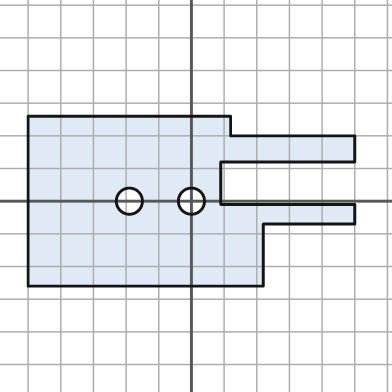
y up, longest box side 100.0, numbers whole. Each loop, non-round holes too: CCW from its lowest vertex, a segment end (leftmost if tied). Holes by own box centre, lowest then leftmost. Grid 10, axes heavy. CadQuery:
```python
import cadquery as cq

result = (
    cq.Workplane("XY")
    .moveTo(-50.0, -26.0)
    .lineTo(22.0, -26.0)
    .lineTo(22.0, -7.0)
    .lineTo(50.0, -7.0)
    .lineTo(50.0, -1.0)
    .lineTo(9.0, -1.0)
    .lineTo(9.0, 12.0)
    .lineTo(50.0, 12.0)
    .lineTo(50.0, 20.0)
    .lineTo(12.0, 20.0)
    .lineTo(12.0, 26.0)
    .lineTo(-50.0, 26.0)
    .close()
    .moveTo(-19.0, 0.0)
    .circle(4.0)
    .moveTo(0.0, 0.0)
    .circle(4.0)
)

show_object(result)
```